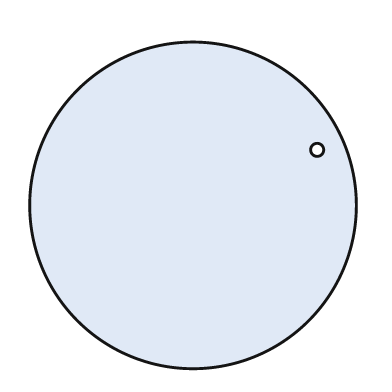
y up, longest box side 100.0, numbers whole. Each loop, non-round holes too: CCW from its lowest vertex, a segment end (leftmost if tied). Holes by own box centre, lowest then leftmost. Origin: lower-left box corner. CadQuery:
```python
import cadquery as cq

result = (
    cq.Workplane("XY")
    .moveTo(50.0, 50.0)
    .circle(50.0)
    .moveTo(88.0, 67.0)
    .circle(2.0)
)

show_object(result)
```